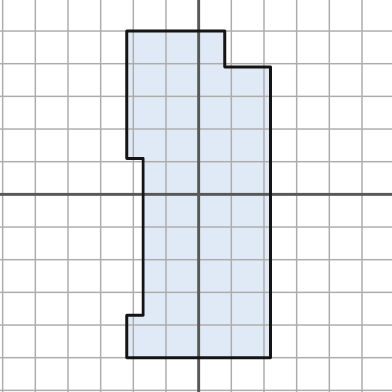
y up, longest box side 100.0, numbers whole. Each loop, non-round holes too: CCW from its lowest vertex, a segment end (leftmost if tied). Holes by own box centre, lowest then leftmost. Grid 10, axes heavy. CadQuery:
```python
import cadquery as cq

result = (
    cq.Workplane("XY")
    .moveTo(-22.0, -50.0)
    .lineTo(22.0, -50.0)
    .lineTo(22.0, 39.0)
    .lineTo(8.0, 39.0)
    .lineTo(8.0, 50.0)
    .lineTo(-22.0, 50.0)
    .lineTo(-22.0, 11.0)
    .lineTo(-17.0, 11.0)
    .lineTo(-17.0, -37.0)
    .lineTo(-22.0, -37.0)
    .close()
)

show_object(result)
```